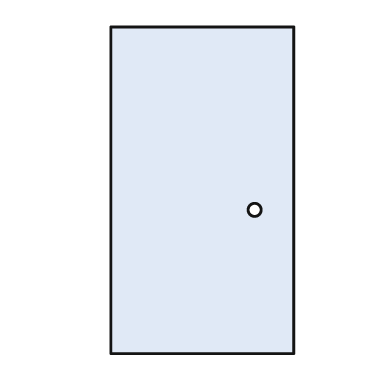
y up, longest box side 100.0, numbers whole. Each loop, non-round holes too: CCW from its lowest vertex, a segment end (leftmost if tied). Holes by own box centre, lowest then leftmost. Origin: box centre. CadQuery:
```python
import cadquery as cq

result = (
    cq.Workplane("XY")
    .moveTo(-28.0, -50.0)
    .lineTo(28.0, -50.0)
    .lineTo(28.0, 50.0)
    .lineTo(-28.0, 50.0)
    .close()
    .moveTo(16.0, -6.0)
    .circle(2.0)
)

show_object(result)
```